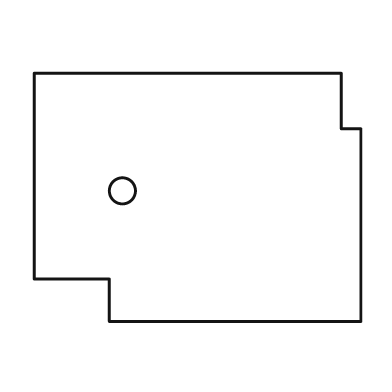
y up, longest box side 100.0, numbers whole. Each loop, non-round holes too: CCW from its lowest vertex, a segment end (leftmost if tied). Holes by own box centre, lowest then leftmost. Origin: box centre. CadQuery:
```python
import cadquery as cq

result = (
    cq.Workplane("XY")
    .moveTo(-27.0, -38.0)
    .lineTo(50.0, -38.0)
    .lineTo(50.0, 21.0)
    .lineTo(44.0, 21.0)
    .lineTo(44.0, 38.0)
    .lineTo(-50.0, 38.0)
    .lineTo(-50.0, -25.0)
    .lineTo(-27.0, -25.0)
    .close()
    .moveTo(-23.0, 2.0)
    .circle(4.0)
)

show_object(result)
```